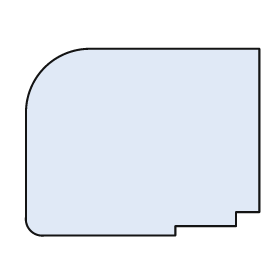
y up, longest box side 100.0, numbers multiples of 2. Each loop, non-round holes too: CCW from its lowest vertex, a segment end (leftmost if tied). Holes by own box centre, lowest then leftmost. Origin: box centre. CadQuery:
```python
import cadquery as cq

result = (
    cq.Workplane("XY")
    .moveTo(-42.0, -40.0)
    .lineTo(14.0, -40.0)
    .lineTo(14.0, -36.0)
    .lineTo(40.0, -36.0)
    .lineTo(40.0, -30.0)
    .lineTo(50.0, -30.0)
    .lineTo(50.0, 40.0)
    .lineTo(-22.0, 40.0)
    .threePointArc((-42.0, 32.0), (-50.0, 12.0))
    .lineTo(-50.0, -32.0)
    .threePointArc((-48.0, -38.0), (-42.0, -40.0))
    .close()
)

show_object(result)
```